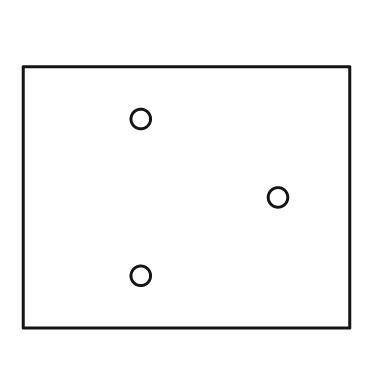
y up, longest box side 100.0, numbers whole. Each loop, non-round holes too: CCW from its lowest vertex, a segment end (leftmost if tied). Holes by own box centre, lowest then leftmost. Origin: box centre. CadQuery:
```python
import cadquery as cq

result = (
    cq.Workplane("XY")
    .moveTo(-50.0, -40.0)
    .lineTo(50.0, -40.0)
    .lineTo(50.0, 40.0)
    .lineTo(-50.0, 40.0)
    .close()
    .moveTo(-14.0, -24.0)
    .circle(3.0)
    .moveTo(28.0, 0.0)
    .circle(3.0)
    .moveTo(-14.0, 24.0)
    .circle(3.0)
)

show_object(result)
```